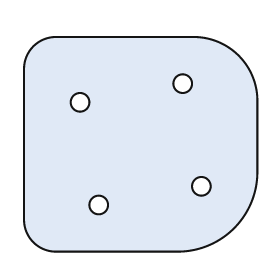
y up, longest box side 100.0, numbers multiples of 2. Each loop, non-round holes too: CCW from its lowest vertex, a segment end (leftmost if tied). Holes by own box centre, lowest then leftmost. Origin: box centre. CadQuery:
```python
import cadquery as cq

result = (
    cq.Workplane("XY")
    .moveTo(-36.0, -46.0)
    .lineTo(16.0, -46.0)
    .threePointArc((40.0, -36.0), (50.0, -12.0))
    .lineTo(50.0, 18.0)
    .threePointArc((42.0, 38.0), (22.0, 46.0))
    .lineTo(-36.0, 46.0)
    .threePointArc((-46.0, 42.0), (-50.0, 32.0))
    .lineTo(-50.0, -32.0)
    .threePointArc((-46.0, -42.0), (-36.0, -46.0))
    .close()
    .moveTo(-18.0, -26.0)
    .circle(4.0)
    .moveTo(26.0, -18.0)
    .circle(4.0)
    .moveTo(-26.0, 18.0)
    .circle(4.0)
    .moveTo(18.0, 26.0)
    .circle(4.0)
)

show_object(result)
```